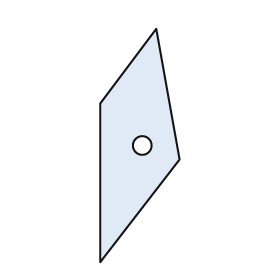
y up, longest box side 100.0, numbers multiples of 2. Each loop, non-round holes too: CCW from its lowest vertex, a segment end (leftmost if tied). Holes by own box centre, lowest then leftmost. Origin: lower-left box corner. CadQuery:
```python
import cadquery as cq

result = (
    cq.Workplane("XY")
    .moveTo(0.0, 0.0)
    .lineTo(34.0, 44.0)
    .lineTo(24.0, 100.0)
    .lineTo(0.0, 68.0)
    .close()
    .moveTo(18.0, 50.0)
    .circle(4.0)
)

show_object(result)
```